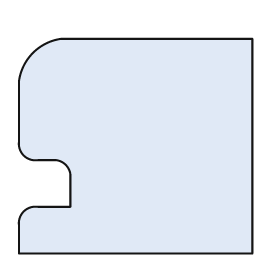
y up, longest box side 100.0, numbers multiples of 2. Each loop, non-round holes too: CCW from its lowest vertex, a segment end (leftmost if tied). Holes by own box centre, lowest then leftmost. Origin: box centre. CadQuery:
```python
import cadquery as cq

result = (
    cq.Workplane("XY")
    .moveTo(-50.0, -46.0)
    .lineTo(50.0, -46.0)
    .lineTo(50.0, 46.0)
    .lineTo(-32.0, 46.0)
    .threePointArc((-44.0, 40.0), (-50.0, 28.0))
    .lineTo(-50.0, 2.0)
    .threePointArc((-48.0, -4.0), (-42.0, -6.0))
    .lineTo(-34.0, -6.0)
    .threePointArc((-30.0, -8.0), (-28.0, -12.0))
    .lineTo(-28.0, -26.0)
    .lineTo(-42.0, -26.0)
    .threePointArc((-48.0, -28.0), (-50.0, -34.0))
    .close()
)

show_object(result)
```